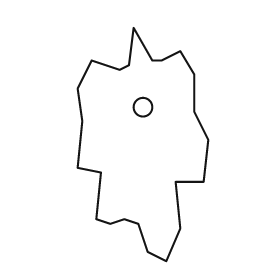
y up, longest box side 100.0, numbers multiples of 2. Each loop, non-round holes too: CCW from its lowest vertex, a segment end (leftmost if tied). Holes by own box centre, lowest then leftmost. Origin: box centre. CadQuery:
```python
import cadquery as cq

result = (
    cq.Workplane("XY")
    .moveTo(10.0, -50.0)
    .lineTo(16.0, -36.0)
    .lineTo(14.0, -16.0)
    .lineTo(26.0, -16.0)
    .lineTo(28.0, 2.0)
    .lineTo(22.0, 14.0)
    .lineTo(22.0, 30.0)
    .lineTo(16.0, 40.0)
    .lineTo(8.0, 36.0)
    .lineTo(4.0, 36.0)
    .lineTo(-4.0, 50.0)
    .lineTo(-6.0, 34.0)
    .lineTo(-10.0, 32.0)
    .lineTo(-22.0, 36.0)
    .lineTo(-28.0, 24.0)
    .lineTo(-26.0, 10.0)
    .lineTo(-28.0, -10.0)
    .lineTo(-18.0, -12.0)
    .lineTo(-20.0, -32.0)
    .lineTo(-14.0, -34.0)
    .lineTo(-8.0, -32.0)
    .lineTo(-2.0, -34.0)
    .lineTo(2.0, -46.0)
    .close()
    .moveTo(0.0, 16.0)
    .circle(4.0)
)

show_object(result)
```